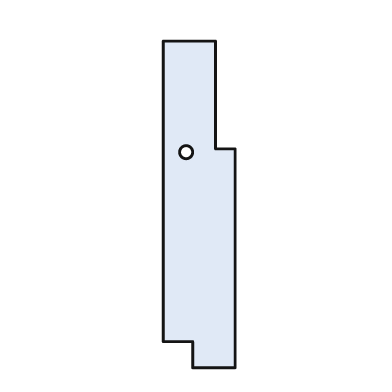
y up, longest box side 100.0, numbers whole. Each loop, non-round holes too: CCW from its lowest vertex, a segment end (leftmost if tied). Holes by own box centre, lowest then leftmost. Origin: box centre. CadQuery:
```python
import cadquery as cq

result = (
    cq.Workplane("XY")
    .moveTo(-2.0, -50.0)
    .lineTo(11.0, -50.0)
    .lineTo(11.0, 17.0)
    .lineTo(5.0, 17.0)
    .lineTo(5.0, 50.0)
    .lineTo(-11.0, 50.0)
    .lineTo(-11.0, -42.0)
    .lineTo(-2.0, -42.0)
    .close()
    .moveTo(-4.0, 16.0)
    .circle(2.0)
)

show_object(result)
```